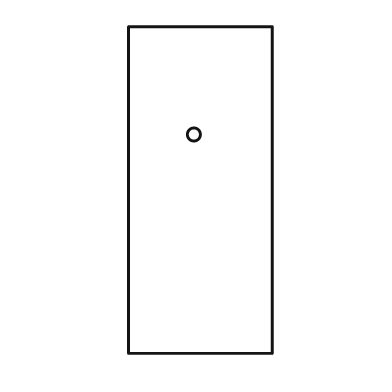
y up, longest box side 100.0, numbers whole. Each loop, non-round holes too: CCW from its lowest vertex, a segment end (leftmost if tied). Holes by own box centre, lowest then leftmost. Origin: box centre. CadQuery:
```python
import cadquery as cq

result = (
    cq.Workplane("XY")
    .moveTo(-22.0, -50.0)
    .lineTo(22.0, -50.0)
    .lineTo(22.0, 50.0)
    .lineTo(-22.0, 50.0)
    .close()
    .moveTo(-2.0, 17.0)
    .circle(2.0)
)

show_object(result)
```